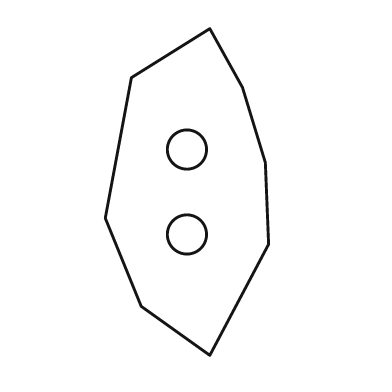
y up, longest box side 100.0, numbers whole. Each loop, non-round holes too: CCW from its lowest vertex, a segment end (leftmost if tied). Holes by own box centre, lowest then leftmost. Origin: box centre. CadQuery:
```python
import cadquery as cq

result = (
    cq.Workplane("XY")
    .moveTo(7.0, -50.0)
    .lineTo(25.0, -16.0)
    .lineTo(24.0, 9.0)
    .lineTo(17.0, 32.0)
    .lineTo(7.0, 50.0)
    .lineTo(-17.0, 35.0)
    .lineTo(-25.0, -8.0)
    .lineTo(-14.0, -35.0)
    .close()
    .moveTo(0.0, -13.0)
    .circle(6.0)
    .moveTo(0.0, 13.0)
    .circle(6.0)
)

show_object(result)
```